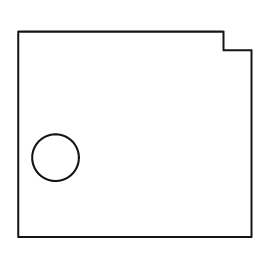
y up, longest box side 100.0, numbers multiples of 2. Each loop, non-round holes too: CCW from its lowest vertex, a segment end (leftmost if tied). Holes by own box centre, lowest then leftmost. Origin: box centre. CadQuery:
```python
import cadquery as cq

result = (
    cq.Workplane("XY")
    .moveTo(-50.0, -44.0)
    .lineTo(50.0, -44.0)
    .lineTo(50.0, 36.0)
    .lineTo(38.0, 36.0)
    .lineTo(38.0, 44.0)
    .lineTo(-50.0, 44.0)
    .close()
    .moveTo(-34.0, -10.0)
    .circle(10.0)
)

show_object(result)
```